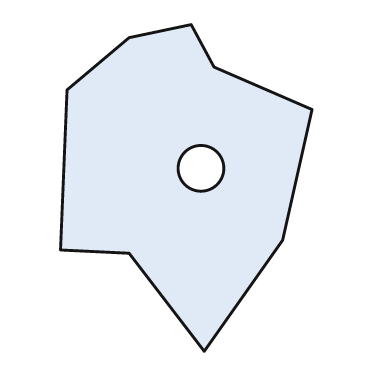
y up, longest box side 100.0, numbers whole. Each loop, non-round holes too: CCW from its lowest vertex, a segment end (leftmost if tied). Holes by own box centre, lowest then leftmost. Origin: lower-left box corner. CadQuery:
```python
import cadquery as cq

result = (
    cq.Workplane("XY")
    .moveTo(44.0, 0.0)
    .lineTo(68.0, 34.0)
    .lineTo(77.0, 74.0)
    .lineTo(47.0, 87.0)
    .lineTo(40.0, 100.0)
    .lineTo(21.0, 96.0)
    .lineTo(2.0, 80.0)
    .lineTo(0.0, 31.0)
    .lineTo(21.0, 30.0)
    .close()
    .moveTo(43.0, 56.0)
    .circle(7.0)
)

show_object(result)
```